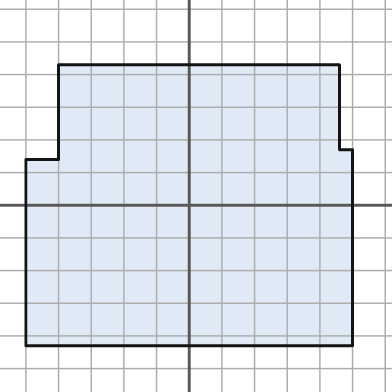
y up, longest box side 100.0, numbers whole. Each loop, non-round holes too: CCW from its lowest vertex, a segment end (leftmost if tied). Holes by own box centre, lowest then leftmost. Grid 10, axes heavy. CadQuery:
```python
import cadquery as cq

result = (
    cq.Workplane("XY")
    .moveTo(-50.0, -43.0)
    .lineTo(50.0, -43.0)
    .lineTo(50.0, 17.0)
    .lineTo(46.0, 17.0)
    .lineTo(46.0, 43.0)
    .lineTo(-40.0, 43.0)
    .lineTo(-40.0, 14.0)
    .lineTo(-50.0, 14.0)
    .close()
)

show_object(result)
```